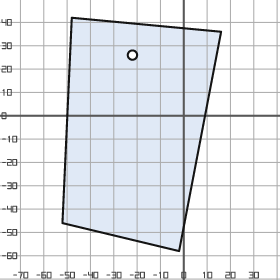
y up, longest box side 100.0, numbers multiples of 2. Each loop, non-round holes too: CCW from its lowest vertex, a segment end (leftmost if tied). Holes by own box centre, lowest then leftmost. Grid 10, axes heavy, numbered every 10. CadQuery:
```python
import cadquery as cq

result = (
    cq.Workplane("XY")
    .moveTo(-2.0, -58.0)
    .lineTo(16.0, 36.0)
    .lineTo(-48.0, 42.0)
    .lineTo(-52.0, -46.0)
    .close()
    .moveTo(-22.0, 26.0)
    .circle(2.0)
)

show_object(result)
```